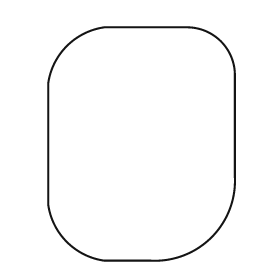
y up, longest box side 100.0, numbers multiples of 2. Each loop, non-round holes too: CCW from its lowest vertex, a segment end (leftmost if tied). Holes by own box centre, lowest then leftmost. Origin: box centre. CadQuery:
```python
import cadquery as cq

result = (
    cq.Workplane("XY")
    .moveTo(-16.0, -50.0)
    .lineTo(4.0, -50.0)
    .threePointArc((30.0, -40.0), (40.0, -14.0))
    .lineTo(40.0, 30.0)
    .threePointArc((34.0, 44.0), (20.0, 50.0))
    .lineTo(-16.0, 50.0)
    .threePointArc((-32.0, 42.0), (-40.0, 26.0))
    .lineTo(-40.0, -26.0)
    .threePointArc((-32.0, -42.0), (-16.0, -50.0))
    .close()
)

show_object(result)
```